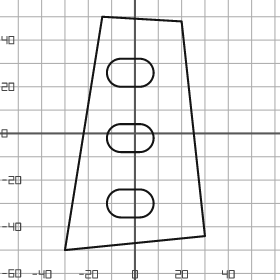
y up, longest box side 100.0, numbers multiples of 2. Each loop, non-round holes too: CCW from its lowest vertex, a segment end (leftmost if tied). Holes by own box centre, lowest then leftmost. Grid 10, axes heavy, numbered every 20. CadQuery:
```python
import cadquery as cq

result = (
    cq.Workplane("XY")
    .moveTo(-30.0, -50.0)
    .lineTo(30.0, -44.0)
    .lineTo(20.0, 48.0)
    .lineTo(-14.0, 50.0)
    .close()
    .moveTo(-6.0, -36.0)
    .lineTo(2.0, -36.0)
    .threePointArc((8.0, -30.0), (2.0, -24.0))
    .lineTo(-6.0, -24.0)
    .threePointArc((-12.0, -30.0), (-6.0, -36.0))
    .close()
    .moveTo(-6.0, -8.0)
    .lineTo(2.0, -8.0)
    .threePointArc((8.0, -2.0), (2.0, 4.0))
    .lineTo(-6.0, 4.0)
    .threePointArc((-12.0, -2.0), (-6.0, -8.0))
    .close()
    .moveTo(-6.0, 20.0)
    .lineTo(2.0, 20.0)
    .threePointArc((8.0, 26.0), (2.0, 32.0))
    .lineTo(-6.0, 32.0)
    .threePointArc((-12.0, 26.0), (-6.0, 20.0))
    .close()
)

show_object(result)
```